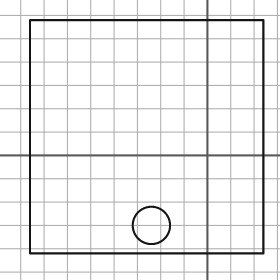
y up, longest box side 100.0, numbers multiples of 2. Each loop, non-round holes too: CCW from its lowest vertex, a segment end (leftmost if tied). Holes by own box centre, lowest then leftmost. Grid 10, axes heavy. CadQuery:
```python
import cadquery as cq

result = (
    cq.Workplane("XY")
    .moveTo(-76.0, -42.0)
    .lineTo(24.0, -42.0)
    .lineTo(24.0, 58.0)
    .lineTo(-76.0, 58.0)
    .close()
    .moveTo(-24.0, -30.0)
    .circle(8.0)
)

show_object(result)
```